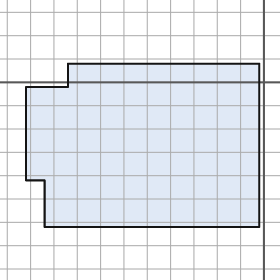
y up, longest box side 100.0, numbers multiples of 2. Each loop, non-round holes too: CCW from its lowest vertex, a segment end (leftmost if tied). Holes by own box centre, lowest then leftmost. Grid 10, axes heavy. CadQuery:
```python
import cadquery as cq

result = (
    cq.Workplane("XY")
    .moveTo(-94.0, -62.0)
    .lineTo(-2.0, -62.0)
    .lineTo(-2.0, 8.0)
    .lineTo(-84.0, 8.0)
    .lineTo(-84.0, -2.0)
    .lineTo(-102.0, -2.0)
    .lineTo(-102.0, -42.0)
    .lineTo(-94.0, -42.0)
    .close()
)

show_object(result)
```